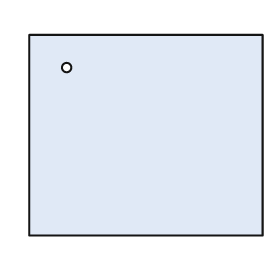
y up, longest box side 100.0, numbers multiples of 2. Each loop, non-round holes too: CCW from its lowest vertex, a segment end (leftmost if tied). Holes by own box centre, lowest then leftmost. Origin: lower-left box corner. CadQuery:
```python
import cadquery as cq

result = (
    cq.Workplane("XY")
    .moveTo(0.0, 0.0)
    .lineTo(100.0, 0.0)
    .lineTo(100.0, 86.0)
    .lineTo(0.0, 86.0)
    .close()
    .moveTo(16.0, 72.0)
    .circle(2.0)
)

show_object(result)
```